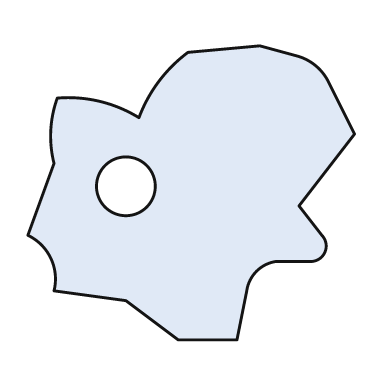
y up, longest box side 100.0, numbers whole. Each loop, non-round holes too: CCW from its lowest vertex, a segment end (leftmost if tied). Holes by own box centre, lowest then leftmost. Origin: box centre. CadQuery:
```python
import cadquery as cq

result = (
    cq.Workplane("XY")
    .moveTo(-4.0, -45.0)
    .lineTo(14.0, -45.0)
    .lineTo(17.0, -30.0)
    .threePointArc((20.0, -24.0), (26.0, -21.0))
    .lineTo(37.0, -21.0)
    .threePointArc((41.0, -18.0), (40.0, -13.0))
    .lineTo(33.0, -4.0)
    .lineTo(50.0, 18.0)
    .lineTo(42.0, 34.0)
    .threePointArc((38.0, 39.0), (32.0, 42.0))
    .lineTo(21.0, 45.0)
    .lineTo(-1.0, 43.0)
    .threePointArc((-10.0, 34.0), (-16.0, 23.0))
    .threePointArc((-28.0, 28.0), (-41.0, 29.0))
    .threePointArc((-43.0, 19.0), (-42.0, 9.0))
    .lineTo(-50.0, -13.0)
    .threePointArc((-43.0, -20.0), (-42.0, -30.0))
    .lineTo(-20.0, -33.0)
    .close()
    .moveTo(-20.0, 2.0)
    .circle(9.0)
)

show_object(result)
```